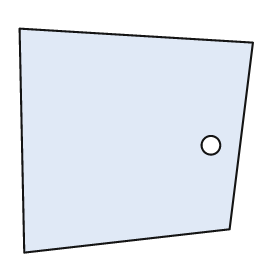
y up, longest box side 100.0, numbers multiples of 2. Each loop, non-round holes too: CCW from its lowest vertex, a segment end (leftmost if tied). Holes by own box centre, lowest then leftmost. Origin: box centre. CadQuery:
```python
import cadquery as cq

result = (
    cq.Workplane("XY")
    .moveTo(-48.0, -48.0)
    .lineTo(40.0, -38.0)
    .lineTo(50.0, 42.0)
    .lineTo(-50.0, 48.0)
    .close()
    .moveTo(32.0, -2.0)
    .circle(4.0)
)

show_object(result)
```